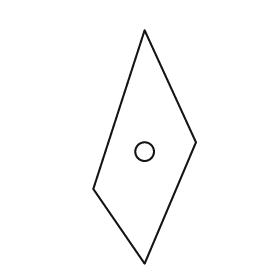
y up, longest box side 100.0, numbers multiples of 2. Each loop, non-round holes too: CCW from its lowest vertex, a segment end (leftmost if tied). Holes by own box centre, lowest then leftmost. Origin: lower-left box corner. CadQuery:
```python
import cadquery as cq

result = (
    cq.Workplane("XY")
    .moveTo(22.0, 0.0)
    .lineTo(44.0, 52.0)
    .lineTo(22.0, 100.0)
    .lineTo(0.0, 32.0)
    .close()
    .moveTo(22.0, 48.0)
    .circle(4.0)
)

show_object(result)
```